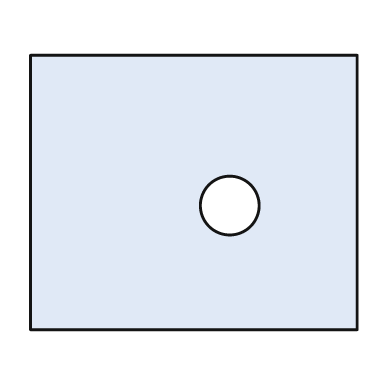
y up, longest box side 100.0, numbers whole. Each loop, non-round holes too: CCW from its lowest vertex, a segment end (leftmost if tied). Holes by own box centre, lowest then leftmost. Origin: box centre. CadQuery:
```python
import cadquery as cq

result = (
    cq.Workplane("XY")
    .moveTo(-50.0, -42.0)
    .lineTo(50.0, -42.0)
    .lineTo(50.0, 42.0)
    .lineTo(-50.0, 42.0)
    .close()
    .moveTo(11.0, -4.0)
    .circle(9.0)
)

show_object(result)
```